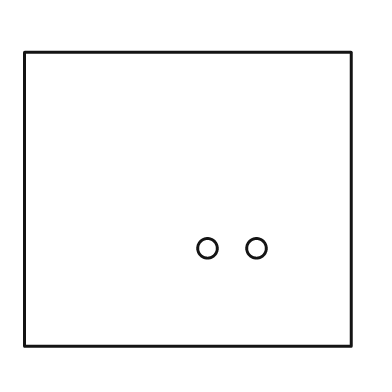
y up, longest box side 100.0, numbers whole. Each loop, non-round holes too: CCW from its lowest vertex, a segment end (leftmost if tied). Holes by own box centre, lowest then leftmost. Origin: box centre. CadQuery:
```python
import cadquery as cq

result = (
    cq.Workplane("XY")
    .moveTo(-50.0, -45.0)
    .lineTo(50.0, -45.0)
    .lineTo(50.0, 45.0)
    .lineTo(-50.0, 45.0)
    .close()
    .moveTo(6.0, -15.0)
    .circle(3.0)
    .moveTo(21.0, -15.0)
    .circle(3.0)
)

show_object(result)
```